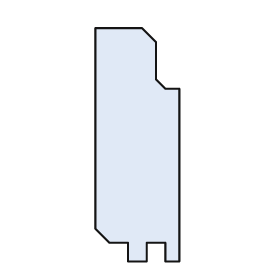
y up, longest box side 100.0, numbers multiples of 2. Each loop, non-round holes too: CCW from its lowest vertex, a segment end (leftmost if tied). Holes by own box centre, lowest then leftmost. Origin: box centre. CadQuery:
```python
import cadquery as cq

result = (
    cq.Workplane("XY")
    .moveTo(-4.0, -50.0)
    .lineTo(4.0, -50.0)
    .lineTo(4.0, -42.0)
    .lineTo(12.0, -42.0)
    .lineTo(12.0, -50.0)
    .lineTo(18.0, -50.0)
    .lineTo(18.0, 24.0)
    .lineTo(12.0, 24.0)
    .lineTo(8.0, 28.0)
    .lineTo(8.0, 44.0)
    .lineTo(2.0, 50.0)
    .lineTo(-18.0, 50.0)
    .lineTo(-18.0, -36.0)
    .lineTo(-12.0, -42.0)
    .lineTo(-4.0, -42.0)
    .close()
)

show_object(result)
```